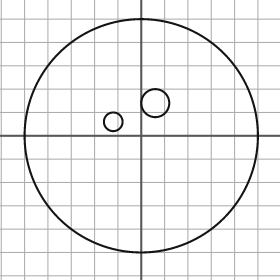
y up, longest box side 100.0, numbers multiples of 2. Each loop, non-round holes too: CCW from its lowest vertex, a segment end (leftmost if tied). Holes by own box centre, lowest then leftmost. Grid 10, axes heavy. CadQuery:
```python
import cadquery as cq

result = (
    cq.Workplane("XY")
    .moveTo(0.0, 0.0)
    .circle(50.0)
    .moveTo(-12.0, 6.0)
    .circle(4.0)
    .moveTo(6.0, 14.0)
    .circle(6.0)
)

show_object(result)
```